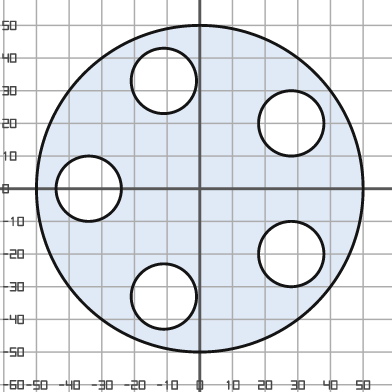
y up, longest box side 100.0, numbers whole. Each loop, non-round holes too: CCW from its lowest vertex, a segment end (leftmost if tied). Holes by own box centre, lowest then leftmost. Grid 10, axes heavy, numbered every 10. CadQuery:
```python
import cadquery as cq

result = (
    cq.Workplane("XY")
    .moveTo(0.0, 0.0)
    .circle(50.0)
    .moveTo(-11.0, -33.0)
    .circle(10.0)
    .moveTo(28.0, -20.0)
    .circle(10.0)
    .moveTo(-34.0, 0.0)
    .circle(10.0)
    .moveTo(28.0, 20.0)
    .circle(10.0)
    .moveTo(-11.0, 33.0)
    .circle(10.0)
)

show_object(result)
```